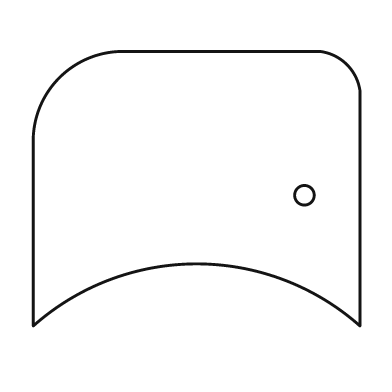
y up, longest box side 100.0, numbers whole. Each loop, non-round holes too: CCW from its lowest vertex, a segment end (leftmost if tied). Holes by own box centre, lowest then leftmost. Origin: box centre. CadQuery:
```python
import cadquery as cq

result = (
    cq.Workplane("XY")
    .moveTo(-50.0, -42.0)
    .threePointArc((0.0, -23.0), (50.0, -42.0))
    .lineTo(50.0, 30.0)
    .threePointArc((46.0, 38.0), (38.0, 42.0))
    .lineTo(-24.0, 42.0)
    .threePointArc((-42.0, 34.0), (-50.0, 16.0))
    .close()
    .moveTo(33.0, -2.0)
    .circle(3.0)
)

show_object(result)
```